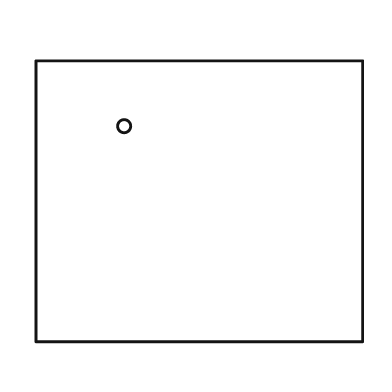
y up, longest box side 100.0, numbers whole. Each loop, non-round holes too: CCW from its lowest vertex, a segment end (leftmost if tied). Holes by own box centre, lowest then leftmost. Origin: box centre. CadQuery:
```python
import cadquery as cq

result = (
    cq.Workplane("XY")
    .moveTo(-50.0, -43.0)
    .lineTo(50.0, -43.0)
    .lineTo(50.0, 43.0)
    .lineTo(-50.0, 43.0)
    .close()
    .moveTo(-23.0, 23.0)
    .circle(2.0)
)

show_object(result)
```